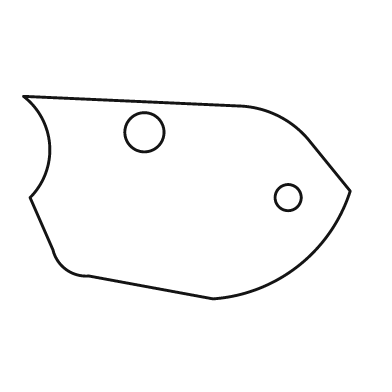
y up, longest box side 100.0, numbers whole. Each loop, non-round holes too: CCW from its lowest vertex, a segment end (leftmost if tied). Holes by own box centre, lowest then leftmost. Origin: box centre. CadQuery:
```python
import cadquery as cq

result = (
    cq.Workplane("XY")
    .moveTo(8.0, -31.0)
    .threePointArc((34.0, -21.0), (50.0, 2.0))
    .lineTo(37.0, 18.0)
    .threePointArc((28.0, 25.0), (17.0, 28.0))
    .lineTo(-50.0, 31.0)
    .threePointArc((-42.0, 16.0), (-48.0, 0.0))
    .lineTo(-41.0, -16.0)
    .threePointArc((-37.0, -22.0), (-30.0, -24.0))
    .close()
    .moveTo(31.0, 0.0)
    .circle(4.0)
    .moveTo(-13.0, 20.0)
    .circle(6.0)
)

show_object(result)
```